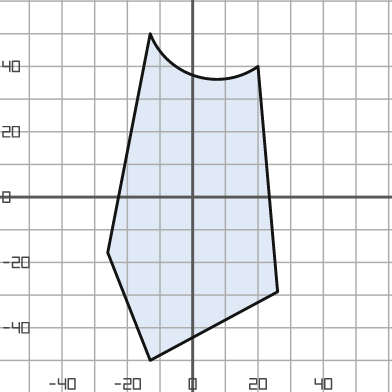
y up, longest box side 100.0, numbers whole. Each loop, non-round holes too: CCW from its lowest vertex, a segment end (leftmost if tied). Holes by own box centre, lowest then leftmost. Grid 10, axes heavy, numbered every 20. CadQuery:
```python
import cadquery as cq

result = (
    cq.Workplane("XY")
    .moveTo(-13.0, -50.0)
    .lineTo(26.0, -29.0)
    .lineTo(20.0, 40.0)
    .threePointArc((1.0, 37.0), (-13.0, 50.0))
    .lineTo(-26.0, -17.0)
    .close()
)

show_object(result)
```